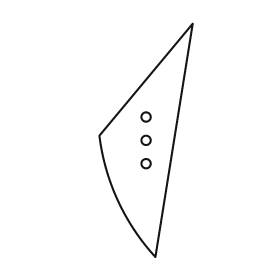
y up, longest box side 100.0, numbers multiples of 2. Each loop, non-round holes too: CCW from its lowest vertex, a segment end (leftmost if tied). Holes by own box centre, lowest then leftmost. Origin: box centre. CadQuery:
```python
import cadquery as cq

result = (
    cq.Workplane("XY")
    .moveTo(4.0, -50.0)
    .lineTo(20.0, 50.0)
    .lineTo(-20.0, 2.0)
    .threePointArc((-12.0, -26.0), (4.0, -50.0))
    .close()
    .moveTo(0.0, -10.0)
    .circle(2.0)
    .moveTo(0.0, 0.0)
    .circle(2.0)
    .moveTo(0.0, 10.0)
    .circle(2.0)
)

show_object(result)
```